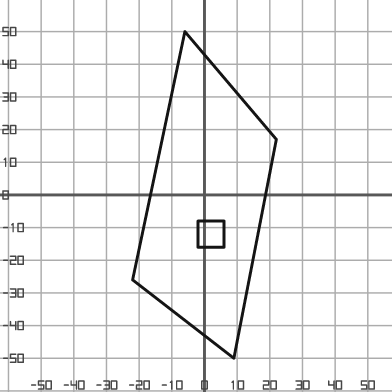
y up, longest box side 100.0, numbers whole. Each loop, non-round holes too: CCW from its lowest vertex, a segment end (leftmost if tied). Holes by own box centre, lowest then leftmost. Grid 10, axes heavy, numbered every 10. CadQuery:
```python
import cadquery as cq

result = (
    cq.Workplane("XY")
    .moveTo(9.0, -50.0)
    .lineTo(22.0, 17.0)
    .lineTo(-6.0, 50.0)
    .lineTo(-22.0, -26.0)
    .close()
    .moveTo(-2.0, -16.0)
    .lineTo(6.0, -16.0)
    .lineTo(6.0, -8.0)
    .lineTo(-2.0, -8.0)
    .close()
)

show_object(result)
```